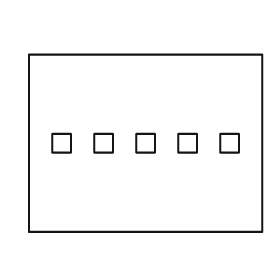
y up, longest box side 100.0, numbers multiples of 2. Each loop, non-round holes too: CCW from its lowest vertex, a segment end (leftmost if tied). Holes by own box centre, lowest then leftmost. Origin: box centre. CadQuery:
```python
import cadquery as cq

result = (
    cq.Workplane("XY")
    .moveTo(-50.0, -38.0)
    .lineTo(50.0, -38.0)
    .lineTo(50.0, 38.0)
    .lineTo(-50.0, 38.0)
    .close()
    .moveTo(-40.0, -4.0)
    .lineTo(-32.0, -4.0)
    .lineTo(-32.0, 4.0)
    .lineTo(-40.0, 4.0)
    .close()
    .moveTo(-22.0, -4.0)
    .lineTo(-14.0, -4.0)
    .lineTo(-14.0, 4.0)
    .lineTo(-22.0, 4.0)
    .close()
    .moveTo(-4.0, -4.0)
    .lineTo(4.0, -4.0)
    .lineTo(4.0, 4.0)
    .lineTo(-4.0, 4.0)
    .close()
    .moveTo(14.0, -4.0)
    .lineTo(22.0, -4.0)
    .lineTo(22.0, 4.0)
    .lineTo(14.0, 4.0)
    .close()
    .moveTo(32.0, -4.0)
    .lineTo(40.0, -4.0)
    .lineTo(40.0, 4.0)
    .lineTo(32.0, 4.0)
    .close()
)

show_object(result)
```